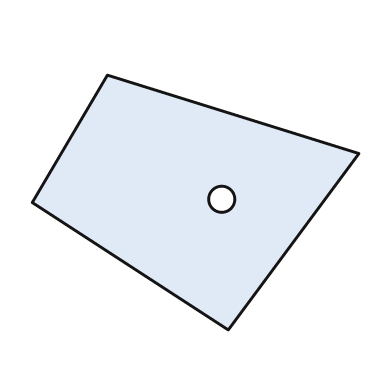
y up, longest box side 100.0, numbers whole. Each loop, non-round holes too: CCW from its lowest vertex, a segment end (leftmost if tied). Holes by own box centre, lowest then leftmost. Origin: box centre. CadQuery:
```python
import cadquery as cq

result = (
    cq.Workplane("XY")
    .moveTo(10.0, -39.0)
    .lineTo(50.0, 15.0)
    .lineTo(-27.0, 39.0)
    .lineTo(-50.0, 0.0)
    .close()
    .moveTo(8.0, 1.0)
    .circle(4.0)
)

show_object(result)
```